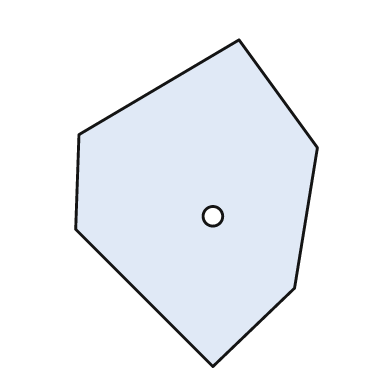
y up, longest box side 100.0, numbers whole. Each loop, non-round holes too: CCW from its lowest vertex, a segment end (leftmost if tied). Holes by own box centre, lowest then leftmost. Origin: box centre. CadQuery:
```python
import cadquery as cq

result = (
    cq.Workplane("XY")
    .moveTo(5.0, -50.0)
    .lineTo(30.0, -26.0)
    .lineTo(37.0, 17.0)
    .lineTo(13.0, 50.0)
    .lineTo(-36.0, 21.0)
    .lineTo(-37.0, -8.0)
    .close()
    .moveTo(5.0, -4.0)
    .circle(3.0)
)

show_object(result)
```